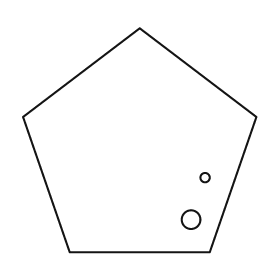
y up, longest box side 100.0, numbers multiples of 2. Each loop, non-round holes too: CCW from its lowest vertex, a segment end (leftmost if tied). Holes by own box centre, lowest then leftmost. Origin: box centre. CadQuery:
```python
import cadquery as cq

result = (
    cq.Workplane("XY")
    .moveTo(-30.0, -48.0)
    .lineTo(30.0, -48.0)
    .lineTo(50.0, 10.0)
    .lineTo(0.0, 48.0)
    .lineTo(-50.0, 10.0)
    .close()
    .moveTo(22.0, -34.0)
    .circle(4.0)
    .moveTo(28.0, -16.0)
    .circle(2.0)
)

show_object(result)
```